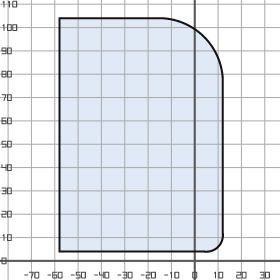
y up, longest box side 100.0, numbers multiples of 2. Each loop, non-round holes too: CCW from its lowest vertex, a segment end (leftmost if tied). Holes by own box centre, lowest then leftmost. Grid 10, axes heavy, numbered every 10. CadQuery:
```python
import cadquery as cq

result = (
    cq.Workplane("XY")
    .moveTo(-58.0, 4.0)
    .lineTo(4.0, 4.0)
    .threePointArc((10.0, 6.0), (12.0, 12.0))
    .lineTo(12.0, 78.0)
    .threePointArc((4.0, 96.0), (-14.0, 104.0))
    .lineTo(-58.0, 104.0)
    .close()
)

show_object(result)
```